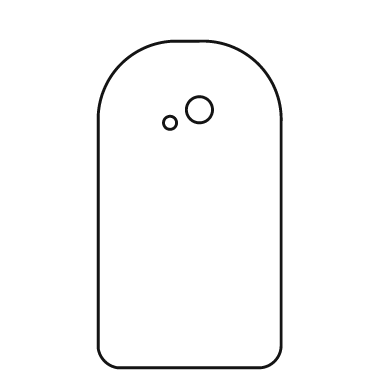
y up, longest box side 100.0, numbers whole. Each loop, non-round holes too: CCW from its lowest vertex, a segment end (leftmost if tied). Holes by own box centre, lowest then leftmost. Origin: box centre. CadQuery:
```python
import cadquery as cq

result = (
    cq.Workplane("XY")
    .moveTo(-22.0, -50.0)
    .lineTo(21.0, -50.0)
    .threePointArc((26.0, -48.0), (28.0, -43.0))
    .lineTo(28.0, 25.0)
    .threePointArc((21.0, 43.0), (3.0, 50.0))
    .lineTo(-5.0, 50.0)
    .threePointArc((-21.0, 43.0), (-28.0, 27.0))
    .lineTo(-28.0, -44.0)
    .threePointArc((-26.0, -48.0), (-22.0, -50.0))
    .close()
    .moveTo(-6.0, 25.0)
    .circle(2.0)
    .moveTo(3.0, 29.0)
    .circle(4.0)
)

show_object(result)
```